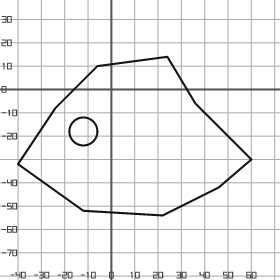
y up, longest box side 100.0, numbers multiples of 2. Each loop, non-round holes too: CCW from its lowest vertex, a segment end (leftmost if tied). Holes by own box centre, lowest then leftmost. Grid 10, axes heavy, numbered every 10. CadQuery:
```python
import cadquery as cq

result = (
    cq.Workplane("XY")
    .moveTo(22.0, -54.0)
    .lineTo(46.0, -42.0)
    .lineTo(60.0, -30.0)
    .lineTo(36.0, -6.0)
    .lineTo(24.0, 14.0)
    .lineTo(-6.0, 10.0)
    .lineTo(-24.0, -8.0)
    .lineTo(-40.0, -32.0)
    .lineTo(-12.0, -52.0)
    .close()
    .moveTo(-12.0, -18.0)
    .circle(6.0)
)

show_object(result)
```